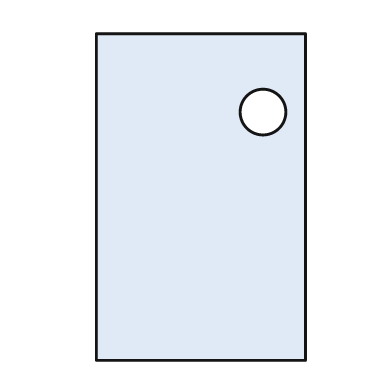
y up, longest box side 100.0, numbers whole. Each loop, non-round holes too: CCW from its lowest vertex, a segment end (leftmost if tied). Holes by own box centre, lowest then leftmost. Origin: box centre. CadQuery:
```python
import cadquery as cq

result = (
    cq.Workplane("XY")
    .moveTo(-32.0, -50.0)
    .lineTo(32.0, -50.0)
    .lineTo(32.0, 50.0)
    .lineTo(-32.0, 50.0)
    .close()
    .moveTo(19.0, 26.0)
    .circle(7.0)
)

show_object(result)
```